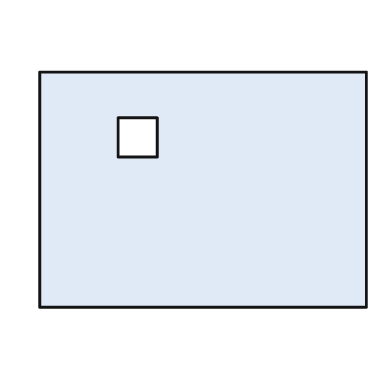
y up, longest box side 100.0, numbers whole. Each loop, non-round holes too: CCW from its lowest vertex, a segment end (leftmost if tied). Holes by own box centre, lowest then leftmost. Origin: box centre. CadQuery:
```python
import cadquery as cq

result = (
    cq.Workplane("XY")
    .moveTo(-50.0, -36.0)
    .lineTo(50.0, -36.0)
    .lineTo(50.0, 36.0)
    .lineTo(-50.0, 36.0)
    .close()
    .moveTo(-26.0, 10.0)
    .lineTo(-14.0, 10.0)
    .lineTo(-14.0, 22.0)
    .lineTo(-26.0, 22.0)
    .close()
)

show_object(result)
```